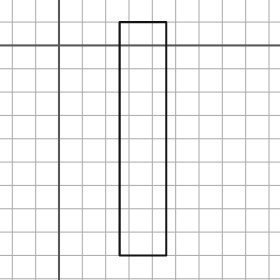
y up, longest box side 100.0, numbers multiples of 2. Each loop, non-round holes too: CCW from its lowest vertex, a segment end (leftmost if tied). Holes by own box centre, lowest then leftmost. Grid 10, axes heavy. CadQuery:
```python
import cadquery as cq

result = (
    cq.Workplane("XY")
    .moveTo(26.0, -90.0)
    .lineTo(46.0, -90.0)
    .lineTo(46.0, 10.0)
    .lineTo(26.0, 10.0)
    .close()
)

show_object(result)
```